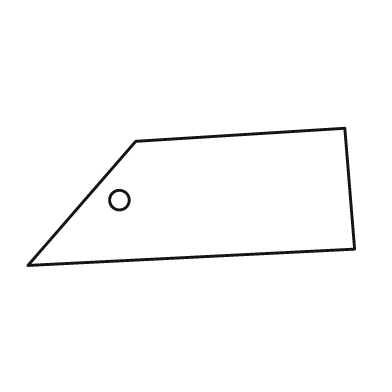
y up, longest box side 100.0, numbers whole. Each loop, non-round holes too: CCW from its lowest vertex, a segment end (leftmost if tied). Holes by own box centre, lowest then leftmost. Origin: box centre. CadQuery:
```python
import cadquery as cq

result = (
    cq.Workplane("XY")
    .moveTo(-50.0, -21.0)
    .lineTo(50.0, -16.0)
    .lineTo(47.0, 21.0)
    .lineTo(-17.0, 17.0)
    .close()
    .moveTo(-22.0, -1.0)
    .circle(3.0)
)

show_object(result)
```